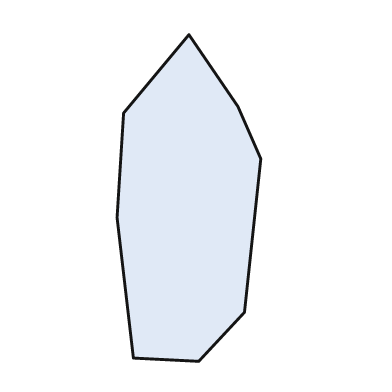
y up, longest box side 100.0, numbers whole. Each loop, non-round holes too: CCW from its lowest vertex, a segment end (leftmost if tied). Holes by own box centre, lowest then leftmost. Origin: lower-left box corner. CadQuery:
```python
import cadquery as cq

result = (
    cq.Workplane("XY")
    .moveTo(25.0, 0.0)
    .lineTo(39.0, 15.0)
    .lineTo(44.0, 62.0)
    .lineTo(37.0, 78.0)
    .lineTo(22.0, 100.0)
    .lineTo(2.0, 76.0)
    .lineTo(0.0, 44.0)
    .lineTo(5.0, 1.0)
    .close()
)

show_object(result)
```